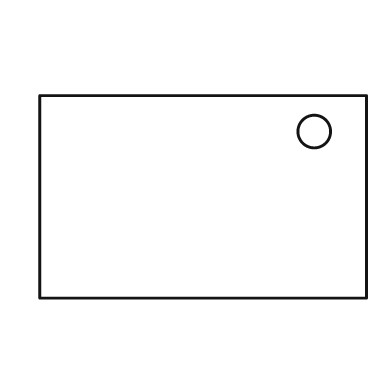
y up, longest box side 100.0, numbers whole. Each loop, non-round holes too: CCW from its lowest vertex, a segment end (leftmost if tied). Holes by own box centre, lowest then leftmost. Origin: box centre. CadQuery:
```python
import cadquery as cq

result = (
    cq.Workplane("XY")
    .moveTo(-50.0, -31.0)
    .lineTo(50.0, -31.0)
    .lineTo(50.0, 31.0)
    .lineTo(-50.0, 31.0)
    .close()
    .moveTo(34.0, 20.0)
    .circle(5.0)
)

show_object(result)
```